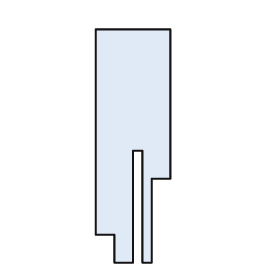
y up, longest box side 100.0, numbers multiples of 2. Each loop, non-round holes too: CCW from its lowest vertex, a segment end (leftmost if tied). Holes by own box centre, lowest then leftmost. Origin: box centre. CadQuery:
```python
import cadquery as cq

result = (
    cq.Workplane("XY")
    .moveTo(-8.0, -50.0)
    .lineTo(0.0, -50.0)
    .lineTo(0.0, -2.0)
    .lineTo(4.0, -2.0)
    .lineTo(4.0, -50.0)
    .lineTo(8.0, -50.0)
    .lineTo(8.0, -14.0)
    .lineTo(16.0, -14.0)
    .lineTo(16.0, 50.0)
    .lineTo(-16.0, 50.0)
    .lineTo(-16.0, -38.0)
    .lineTo(-8.0, -38.0)
    .close()
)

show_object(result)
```